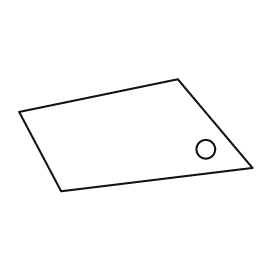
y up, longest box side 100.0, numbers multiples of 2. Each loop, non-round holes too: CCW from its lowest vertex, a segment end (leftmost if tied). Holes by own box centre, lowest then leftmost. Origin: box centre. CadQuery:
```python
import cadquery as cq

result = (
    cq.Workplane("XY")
    .moveTo(-32.0, -24.0)
    .lineTo(50.0, -14.0)
    .lineTo(18.0, 24.0)
    .lineTo(-50.0, 10.0)
    .close()
    .moveTo(30.0, -6.0)
    .circle(4.0)
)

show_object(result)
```